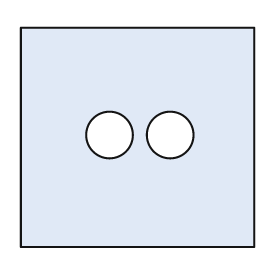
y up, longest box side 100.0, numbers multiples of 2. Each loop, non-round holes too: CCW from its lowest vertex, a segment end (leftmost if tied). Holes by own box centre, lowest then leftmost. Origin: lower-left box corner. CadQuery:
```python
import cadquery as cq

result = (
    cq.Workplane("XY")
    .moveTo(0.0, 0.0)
    .lineTo(100.0, 0.0)
    .lineTo(100.0, 94.0)
    .lineTo(0.0, 94.0)
    .close()
    .moveTo(38.0, 48.0)
    .circle(10.0)
    .moveTo(64.0, 48.0)
    .circle(10.0)
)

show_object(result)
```